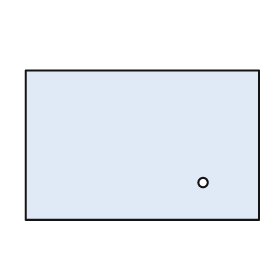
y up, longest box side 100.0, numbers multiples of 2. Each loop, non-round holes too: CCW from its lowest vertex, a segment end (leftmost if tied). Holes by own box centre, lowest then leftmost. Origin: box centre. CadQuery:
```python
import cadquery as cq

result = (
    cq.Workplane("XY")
    .moveTo(-50.0, -32.0)
    .lineTo(50.0, -32.0)
    .lineTo(50.0, 32.0)
    .lineTo(-50.0, 32.0)
    .close()
    .moveTo(26.0, -16.0)
    .circle(2.0)
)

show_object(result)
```